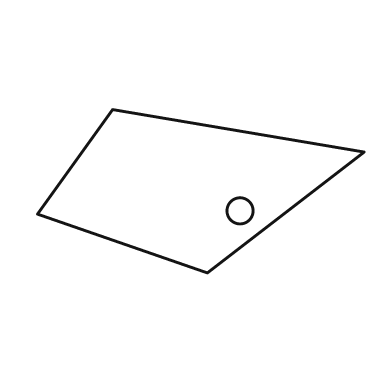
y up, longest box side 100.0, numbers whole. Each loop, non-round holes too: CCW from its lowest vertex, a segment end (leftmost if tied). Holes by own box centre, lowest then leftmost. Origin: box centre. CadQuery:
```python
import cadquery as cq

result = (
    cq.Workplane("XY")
    .moveTo(2.0, -25.0)
    .lineTo(50.0, 12.0)
    .lineTo(-27.0, 25.0)
    .lineTo(-50.0, -7.0)
    .close()
    .moveTo(12.0, -6.0)
    .circle(4.0)
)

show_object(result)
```